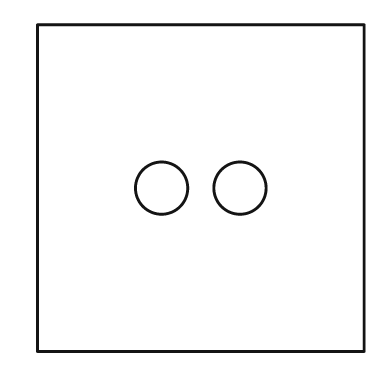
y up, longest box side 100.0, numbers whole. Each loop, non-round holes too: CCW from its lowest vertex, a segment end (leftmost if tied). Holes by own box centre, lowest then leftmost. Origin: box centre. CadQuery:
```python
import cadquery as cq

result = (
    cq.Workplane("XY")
    .moveTo(-50.0, -50.0)
    .lineTo(50.0, -50.0)
    .lineTo(50.0, 50.0)
    .lineTo(-50.0, 50.0)
    .close()
    .moveTo(-12.0, 0.0)
    .circle(8.0)
    .moveTo(12.0, 0.0)
    .circle(8.0)
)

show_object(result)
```